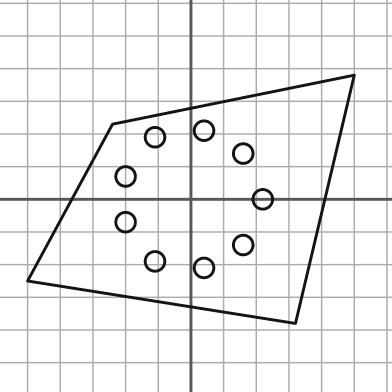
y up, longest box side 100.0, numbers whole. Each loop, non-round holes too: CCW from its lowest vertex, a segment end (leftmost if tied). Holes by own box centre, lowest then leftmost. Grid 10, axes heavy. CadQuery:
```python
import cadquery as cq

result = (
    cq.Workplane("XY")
    .moveTo(32.0, -38.0)
    .lineTo(50.0, 38.0)
    .lineTo(-24.0, 23.0)
    .lineTo(-50.0, -25.0)
    .close()
    .moveTo(4.0, -21.0)
    .circle(3.0)
    .moveTo(-11.0, -19.0)
    .circle(3.0)
    .moveTo(16.0, -14.0)
    .circle(3.0)
    .moveTo(-20.0, -7.0)
    .circle(3.0)
    .moveTo(22.0, 0.0)
    .circle(3.0)
    .moveTo(-20.0, 7.0)
    .circle(3.0)
    .moveTo(16.0, 14.0)
    .circle(3.0)
    .moveTo(-11.0, 19.0)
    .circle(3.0)
    .moveTo(4.0, 21.0)
    .circle(3.0)
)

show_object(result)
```